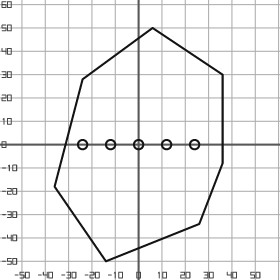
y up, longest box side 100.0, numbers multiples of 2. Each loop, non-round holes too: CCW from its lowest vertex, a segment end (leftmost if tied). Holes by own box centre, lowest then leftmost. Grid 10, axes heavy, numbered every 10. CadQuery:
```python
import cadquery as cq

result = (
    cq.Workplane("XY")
    .moveTo(-14.0, -50.0)
    .lineTo(26.0, -34.0)
    .lineTo(36.0, -8.0)
    .lineTo(36.0, 30.0)
    .lineTo(6.0, 50.0)
    .lineTo(-24.0, 28.0)
    .lineTo(-36.0, -18.0)
    .close()
    .moveTo(-24.0, 0.0)
    .circle(2.0)
    .moveTo(-12.0, 0.0)
    .circle(2.0)
    .moveTo(0.0, 0.0)
    .circle(2.0)
    .moveTo(12.0, 0.0)
    .circle(2.0)
    .moveTo(24.0, 0.0)
    .circle(2.0)
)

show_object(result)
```